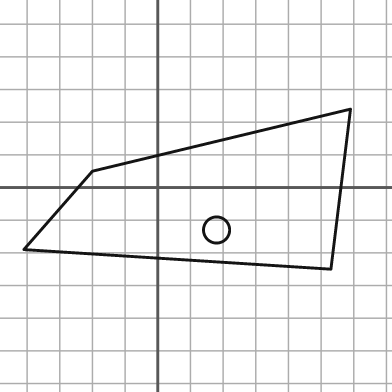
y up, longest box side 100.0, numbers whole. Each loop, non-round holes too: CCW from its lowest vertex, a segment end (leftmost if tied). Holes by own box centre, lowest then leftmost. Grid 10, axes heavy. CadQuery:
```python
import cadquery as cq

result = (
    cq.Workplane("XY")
    .moveTo(53.0, -25.0)
    .lineTo(59.0, 24.0)
    .lineTo(-20.0, 5.0)
    .lineTo(-41.0, -19.0)
    .close()
    .moveTo(18.0, -13.0)
    .circle(4.0)
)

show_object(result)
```